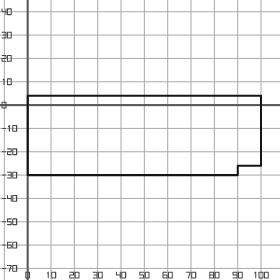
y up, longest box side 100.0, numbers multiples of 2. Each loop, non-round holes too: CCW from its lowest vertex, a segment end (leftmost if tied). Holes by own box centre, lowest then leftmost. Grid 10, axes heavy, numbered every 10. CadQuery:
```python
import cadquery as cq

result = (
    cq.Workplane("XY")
    .moveTo(0.0, -30.0)
    .lineTo(90.0, -30.0)
    .lineTo(90.0, -26.0)
    .lineTo(100.0, -26.0)
    .lineTo(100.0, 4.0)
    .lineTo(0.0, 4.0)
    .close()
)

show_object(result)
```